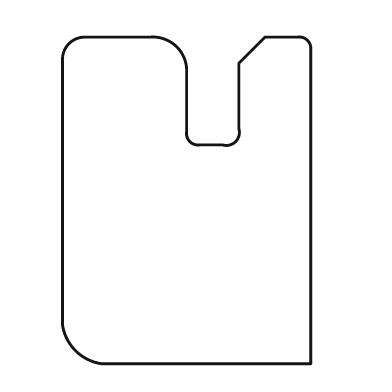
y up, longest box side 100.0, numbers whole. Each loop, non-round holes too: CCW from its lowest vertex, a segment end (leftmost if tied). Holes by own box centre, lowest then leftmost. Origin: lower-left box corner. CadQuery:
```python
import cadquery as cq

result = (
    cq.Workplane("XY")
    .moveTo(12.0, 0.0)
    .lineTo(76.0, 0.0)
    .lineTo(76.0, 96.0)
    .threePointArc((75.0, 99.0), (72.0, 100.0))
    .lineTo(62.0, 100.0)
    .lineTo(54.0, 92.0)
    .lineTo(54.0, 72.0)
    .threePointArc((53.0, 68.0), (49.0, 67.0))
    .lineTo(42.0, 67.0)
    .threePointArc((39.0, 68.0), (38.0, 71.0))
    .lineTo(38.0, 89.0)
    .threePointArc((35.0, 97.0), (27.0, 100.0))
    .lineTo(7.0, 100.0)
    .threePointArc((2.0, 98.0), (0.0, 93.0))
    .lineTo(0.0, 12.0)
    .threePointArc((4.0, 4.0), (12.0, 0.0))
    .close()
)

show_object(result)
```